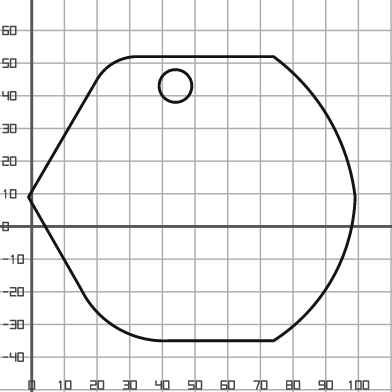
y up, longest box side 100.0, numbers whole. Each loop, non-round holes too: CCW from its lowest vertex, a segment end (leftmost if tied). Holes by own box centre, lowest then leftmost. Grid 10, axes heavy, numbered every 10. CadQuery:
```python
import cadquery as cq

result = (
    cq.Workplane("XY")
    .moveTo(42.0, -35.0)
    .lineTo(74.0, -35.0)
    .threePointArc((92.0, -16.0), (99.0, 9.0))
    .threePointArc((91.0, 33.0), (74.0, 52.0))
    .lineTo(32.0, 52.0)
    .threePointArc((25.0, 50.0), (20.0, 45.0))
    .lineTo(-1.0, 9.0)
    .lineTo(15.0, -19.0)
    .threePointArc((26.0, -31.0), (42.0, -35.0))
    .close()
    .moveTo(44.0, 43.0)
    .circle(5.0)
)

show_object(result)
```